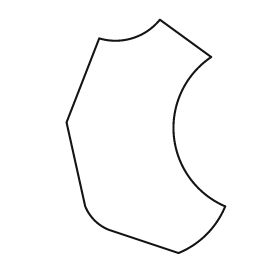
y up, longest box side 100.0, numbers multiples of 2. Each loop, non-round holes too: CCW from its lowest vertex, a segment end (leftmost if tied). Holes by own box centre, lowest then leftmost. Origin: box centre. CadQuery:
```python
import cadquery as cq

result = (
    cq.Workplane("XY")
    .moveTo(14.0, -50.0)
    .threePointArc((26.0, -42.0), (34.0, -30.0))
    .threePointArc((12.0, 0.0), (28.0, 34.0))
    .lineTo(6.0, 50.0)
    .threePointArc((-6.0, 42.0), (-20.0, 42.0))
    .lineTo(-34.0, 6.0)
    .lineTo(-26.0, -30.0)
    .threePointArc((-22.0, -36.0), (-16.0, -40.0))
    .close()
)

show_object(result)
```